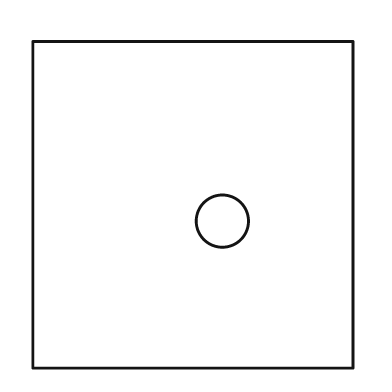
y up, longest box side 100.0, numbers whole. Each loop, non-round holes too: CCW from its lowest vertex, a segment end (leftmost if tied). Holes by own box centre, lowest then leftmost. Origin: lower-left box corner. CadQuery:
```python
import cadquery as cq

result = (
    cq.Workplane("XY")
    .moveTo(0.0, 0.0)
    .lineTo(98.0, 0.0)
    .lineTo(98.0, 100.0)
    .lineTo(0.0, 100.0)
    .close()
    .moveTo(58.0, 45.0)
    .circle(8.0)
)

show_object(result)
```